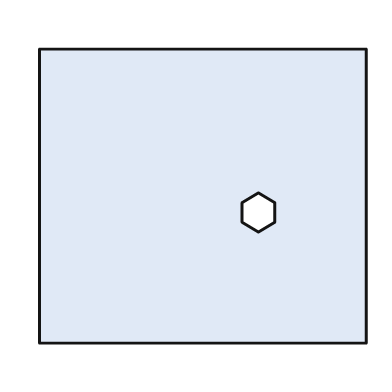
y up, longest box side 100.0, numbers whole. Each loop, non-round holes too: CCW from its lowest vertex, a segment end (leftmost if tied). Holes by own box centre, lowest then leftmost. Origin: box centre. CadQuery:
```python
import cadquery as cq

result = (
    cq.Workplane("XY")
    .moveTo(-50.0, -45.0)
    .lineTo(50.0, -45.0)
    .lineTo(50.0, 45.0)
    .lineTo(-50.0, 45.0)
    .close()
    .moveTo(17.0, -11.0)
    .lineTo(22.0, -8.0)
    .lineTo(22.0, -2.0)
    .lineTo(17.0, 1.0)
    .lineTo(12.0, -2.0)
    .lineTo(12.0, -8.0)
    .close()
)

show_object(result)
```